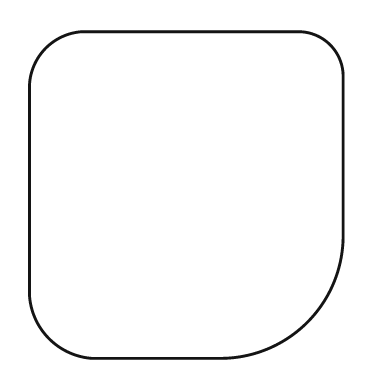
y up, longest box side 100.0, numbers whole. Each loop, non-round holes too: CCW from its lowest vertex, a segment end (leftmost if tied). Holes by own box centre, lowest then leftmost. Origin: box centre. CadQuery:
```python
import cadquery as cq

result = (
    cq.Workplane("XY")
    .moveTo(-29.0, -50.0)
    .lineTo(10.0, -50.0)
    .threePointArc((37.0, -39.0), (48.0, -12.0))
    .lineTo(48.0, 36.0)
    .threePointArc((44.0, 46.0), (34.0, 50.0))
    .lineTo(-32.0, 50.0)
    .threePointArc((-43.0, 45.0), (-48.0, 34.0))
    .lineTo(-48.0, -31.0)
    .threePointArc((-42.0, -44.0), (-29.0, -50.0))
    .close()
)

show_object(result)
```